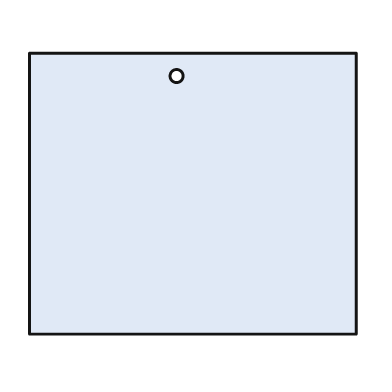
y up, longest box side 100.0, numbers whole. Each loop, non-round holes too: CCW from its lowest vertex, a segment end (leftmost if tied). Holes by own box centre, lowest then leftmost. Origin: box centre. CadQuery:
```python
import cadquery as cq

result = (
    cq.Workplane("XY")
    .moveTo(-50.0, -43.0)
    .lineTo(50.0, -43.0)
    .lineTo(50.0, 43.0)
    .lineTo(-50.0, 43.0)
    .close()
    .moveTo(-5.0, 36.0)
    .circle(2.0)
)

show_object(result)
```